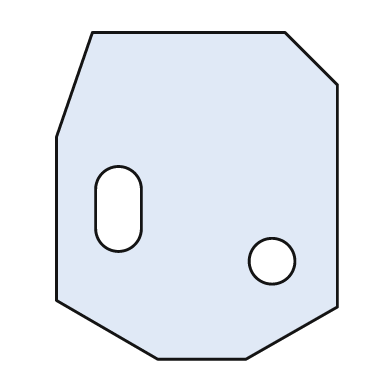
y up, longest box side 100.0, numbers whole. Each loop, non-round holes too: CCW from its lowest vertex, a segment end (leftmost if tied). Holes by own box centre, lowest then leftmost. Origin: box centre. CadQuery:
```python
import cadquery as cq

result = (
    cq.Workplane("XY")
    .moveTo(-12.0, -50.0)
    .lineTo(15.0, -50.0)
    .lineTo(43.0, -34.0)
    .lineTo(43.0, 34.0)
    .lineTo(27.0, 50.0)
    .lineTo(-32.0, 50.0)
    .lineTo(-43.0, 18.0)
    .lineTo(-43.0, -32.0)
    .close()
    .moveTo(23.0, -20.0)
    .circle(7.0)
    .moveTo(-31.0, -10.0)
    .threePointArc((-24.0, -17.0), (-17.0, -10.0))
    .lineTo(-17.0, 2.0)
    .threePointArc((-24.0, 9.0), (-31.0, 2.0))
    .close()
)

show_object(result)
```